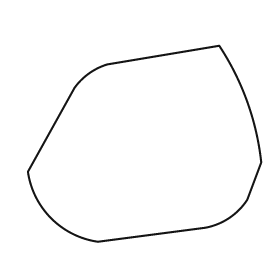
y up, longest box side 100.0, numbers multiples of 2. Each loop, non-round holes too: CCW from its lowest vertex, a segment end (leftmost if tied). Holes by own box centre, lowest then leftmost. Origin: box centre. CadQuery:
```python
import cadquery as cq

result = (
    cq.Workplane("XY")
    .moveTo(-20.0, -42.0)
    .lineTo(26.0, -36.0)
    .threePointArc((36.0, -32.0), (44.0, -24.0))
    .lineTo(50.0, -8.0)
    .threePointArc((44.0, 18.0), (32.0, 42.0))
    .lineTo(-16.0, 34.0)
    .threePointArc((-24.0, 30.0), (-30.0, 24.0))
    .lineTo(-50.0, -12.0)
    .threePointArc((-40.0, -32.0), (-20.0, -42.0))
    .close()
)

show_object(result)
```